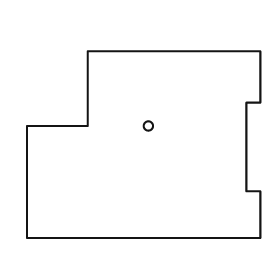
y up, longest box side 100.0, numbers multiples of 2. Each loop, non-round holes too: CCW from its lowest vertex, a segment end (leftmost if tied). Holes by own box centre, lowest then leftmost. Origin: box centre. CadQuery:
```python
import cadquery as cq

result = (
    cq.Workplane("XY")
    .moveTo(-50.0, -40.0)
    .lineTo(50.0, -40.0)
    .lineTo(50.0, -20.0)
    .lineTo(44.0, -20.0)
    .lineTo(44.0, 18.0)
    .lineTo(50.0, 18.0)
    .lineTo(50.0, 40.0)
    .lineTo(-24.0, 40.0)
    .lineTo(-24.0, 8.0)
    .lineTo(-50.0, 8.0)
    .close()
    .moveTo(2.0, 8.0)
    .circle(2.0)
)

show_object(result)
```